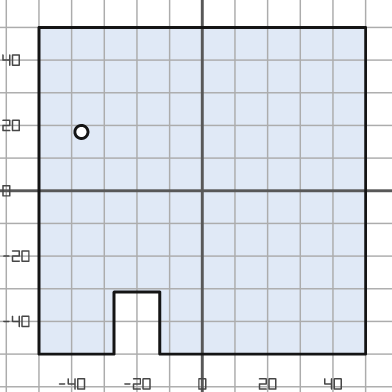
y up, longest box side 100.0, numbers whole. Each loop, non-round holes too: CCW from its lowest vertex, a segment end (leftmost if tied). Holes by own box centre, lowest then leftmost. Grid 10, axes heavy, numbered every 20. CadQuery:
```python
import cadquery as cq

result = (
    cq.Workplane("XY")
    .moveTo(-50.0, -50.0)
    .lineTo(-27.0, -50.0)
    .lineTo(-27.0, -31.0)
    .lineTo(-13.0, -31.0)
    .lineTo(-13.0, -50.0)
    .lineTo(50.0, -50.0)
    .lineTo(50.0, 50.0)
    .lineTo(-50.0, 50.0)
    .close()
    .moveTo(-37.0, 18.0)
    .circle(2.0)
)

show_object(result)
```